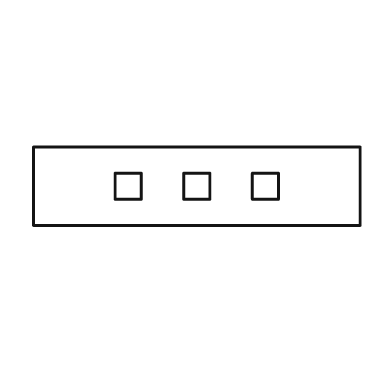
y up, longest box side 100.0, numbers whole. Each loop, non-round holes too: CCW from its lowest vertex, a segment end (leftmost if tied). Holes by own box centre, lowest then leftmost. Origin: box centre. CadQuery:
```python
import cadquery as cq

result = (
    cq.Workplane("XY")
    .moveTo(-50.0, -12.0)
    .lineTo(50.0, -12.0)
    .lineTo(50.0, 12.0)
    .lineTo(-50.0, 12.0)
    .close()
    .moveTo(-25.0, -4.0)
    .lineTo(-17.0, -4.0)
    .lineTo(-17.0, 4.0)
    .lineTo(-25.0, 4.0)
    .close()
    .moveTo(-4.0, -4.0)
    .lineTo(4.0, -4.0)
    .lineTo(4.0, 4.0)
    .lineTo(-4.0, 4.0)
    .close()
    .moveTo(17.0, -4.0)
    .lineTo(25.0, -4.0)
    .lineTo(25.0, 4.0)
    .lineTo(17.0, 4.0)
    .close()
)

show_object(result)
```